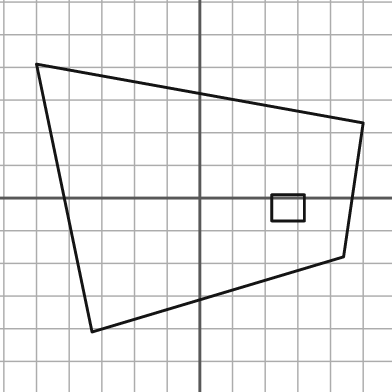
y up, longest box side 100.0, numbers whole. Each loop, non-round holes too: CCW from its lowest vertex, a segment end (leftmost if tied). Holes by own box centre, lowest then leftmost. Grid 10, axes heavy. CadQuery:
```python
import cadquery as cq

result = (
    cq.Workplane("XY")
    .moveTo(-33.0, -41.0)
    .lineTo(44.0, -18.0)
    .lineTo(50.0, 23.0)
    .lineTo(-50.0, 41.0)
    .close()
    .moveTo(22.0, -7.0)
    .lineTo(32.0, -7.0)
    .lineTo(32.0, 1.0)
    .lineTo(22.0, 1.0)
    .close()
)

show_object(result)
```